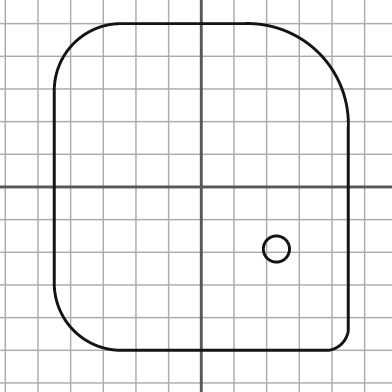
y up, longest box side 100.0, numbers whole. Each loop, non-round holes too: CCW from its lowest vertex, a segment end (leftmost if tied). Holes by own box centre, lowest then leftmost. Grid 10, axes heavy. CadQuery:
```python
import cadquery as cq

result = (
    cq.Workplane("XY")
    .moveTo(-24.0, -50.0)
    .lineTo(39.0, -50.0)
    .threePointArc((43.0, -48.0), (45.0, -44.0))
    .lineTo(45.0, 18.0)
    .threePointArc((36.0, 41.0), (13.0, 50.0))
    .lineTo(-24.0, 50.0)
    .threePointArc((-39.0, 44.0), (-45.0, 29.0))
    .lineTo(-45.0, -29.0)
    .threePointArc((-39.0, -44.0), (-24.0, -50.0))
    .close()
    .moveTo(23.0, -19.0)
    .circle(4.0)
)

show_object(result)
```